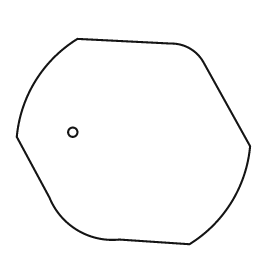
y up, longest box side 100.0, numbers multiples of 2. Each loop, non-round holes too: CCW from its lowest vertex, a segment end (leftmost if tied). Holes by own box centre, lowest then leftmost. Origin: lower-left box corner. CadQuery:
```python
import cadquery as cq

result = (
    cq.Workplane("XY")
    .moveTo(74.0, 0.0)
    .threePointArc((92.0, 18.0), (100.0, 42.0))
    .lineTo(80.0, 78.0)
    .threePointArc((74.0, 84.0), (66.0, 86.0))
    .lineTo(26.0, 88.0)
    .threePointArc((8.0, 70.0), (0.0, 46.0))
    .lineTo(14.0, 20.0)
    .threePointArc((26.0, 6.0), (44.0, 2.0))
    .close()
    .moveTo(24.0, 48.0)
    .circle(2.0)
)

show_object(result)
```